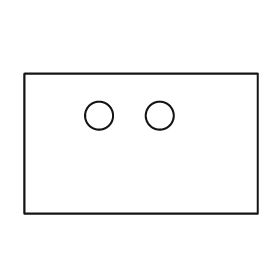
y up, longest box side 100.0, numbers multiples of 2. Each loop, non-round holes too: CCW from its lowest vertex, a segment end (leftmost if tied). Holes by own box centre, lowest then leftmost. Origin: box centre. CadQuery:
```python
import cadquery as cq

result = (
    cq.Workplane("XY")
    .moveTo(-50.0, -30.0)
    .lineTo(50.0, -30.0)
    .lineTo(50.0, 30.0)
    .lineTo(-50.0, 30.0)
    .close()
    .moveTo(-18.0, 12.0)
    .circle(6.0)
    .moveTo(8.0, 12.0)
    .circle(6.0)
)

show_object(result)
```